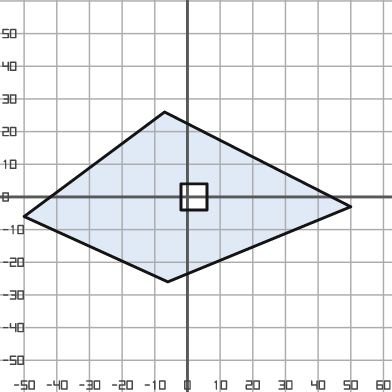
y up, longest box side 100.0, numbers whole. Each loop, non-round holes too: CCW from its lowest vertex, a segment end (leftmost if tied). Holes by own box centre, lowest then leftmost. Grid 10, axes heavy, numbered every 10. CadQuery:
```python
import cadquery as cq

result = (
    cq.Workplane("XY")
    .moveTo(-6.0, -26.0)
    .lineTo(50.0, -3.0)
    .lineTo(-7.0, 26.0)
    .lineTo(-50.0, -6.0)
    .close()
    .moveTo(-2.0, -4.0)
    .lineTo(6.0, -4.0)
    .lineTo(6.0, 4.0)
    .lineTo(-2.0, 4.0)
    .close()
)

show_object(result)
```